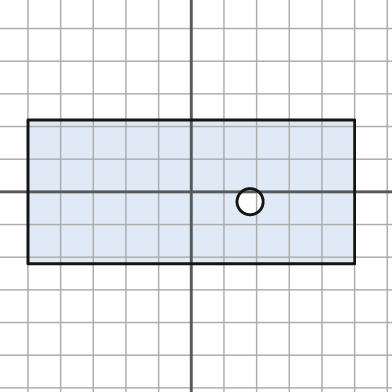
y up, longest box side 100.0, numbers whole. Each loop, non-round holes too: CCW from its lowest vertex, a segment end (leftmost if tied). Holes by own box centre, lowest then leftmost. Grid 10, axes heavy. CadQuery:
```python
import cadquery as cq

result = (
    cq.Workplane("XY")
    .moveTo(-50.0, -22.0)
    .lineTo(50.0, -22.0)
    .lineTo(50.0, 22.0)
    .lineTo(-50.0, 22.0)
    .close()
    .moveTo(18.0, -3.0)
    .circle(4.0)
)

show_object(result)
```